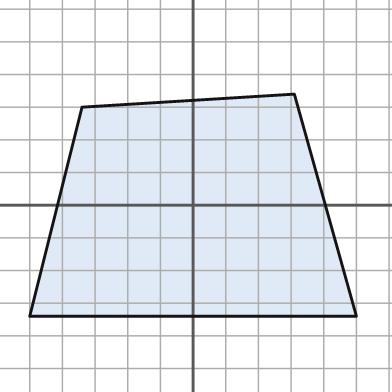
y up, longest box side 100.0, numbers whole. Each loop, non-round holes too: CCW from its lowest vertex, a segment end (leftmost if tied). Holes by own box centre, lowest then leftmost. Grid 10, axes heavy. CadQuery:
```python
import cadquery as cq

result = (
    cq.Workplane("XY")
    .moveTo(-50.0, -34.0)
    .lineTo(50.0, -34.0)
    .lineTo(31.0, 34.0)
    .lineTo(-34.0, 30.0)
    .close()
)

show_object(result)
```